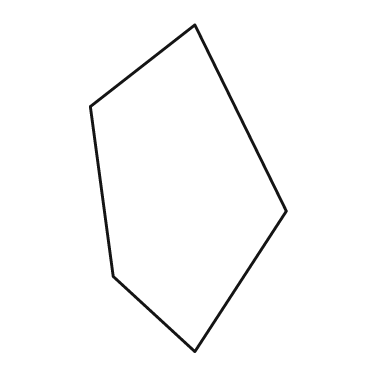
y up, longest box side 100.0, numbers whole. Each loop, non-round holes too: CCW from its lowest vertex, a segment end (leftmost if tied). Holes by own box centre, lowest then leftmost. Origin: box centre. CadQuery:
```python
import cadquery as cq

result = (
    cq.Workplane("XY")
    .moveTo(2.0, -50.0)
    .lineTo(30.0, -7.0)
    .lineTo(2.0, 50.0)
    .lineTo(-30.0, 25.0)
    .lineTo(-23.0, -27.0)
    .close()
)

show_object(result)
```